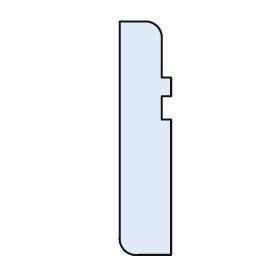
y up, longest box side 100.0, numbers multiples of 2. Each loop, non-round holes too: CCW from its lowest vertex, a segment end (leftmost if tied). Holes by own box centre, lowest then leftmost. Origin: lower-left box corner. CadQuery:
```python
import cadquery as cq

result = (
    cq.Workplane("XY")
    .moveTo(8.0, 0.0)
    .lineTo(22.0, 0.0)
    .lineTo(22.0, 58.0)
    .lineTo(18.0, 58.0)
    .lineTo(18.0, 68.0)
    .lineTo(22.0, 68.0)
    .lineTo(22.0, 76.0)
    .lineTo(18.0, 76.0)
    .lineTo(18.0, 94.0)
    .threePointArc((16.0, 98.0), (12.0, 100.0))
    .lineTo(0.0, 100.0)
    .lineTo(0.0, 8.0)
    .threePointArc((2.0, 2.0), (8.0, 0.0))
    .close()
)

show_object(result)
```